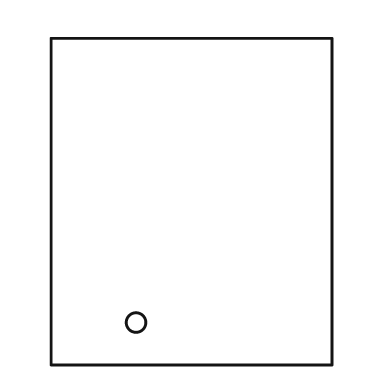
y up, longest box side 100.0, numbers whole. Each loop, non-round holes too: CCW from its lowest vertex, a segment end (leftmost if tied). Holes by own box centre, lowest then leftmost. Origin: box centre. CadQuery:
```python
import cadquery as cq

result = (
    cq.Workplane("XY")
    .moveTo(-43.0, -50.0)
    .lineTo(43.0, -50.0)
    .lineTo(43.0, 50.0)
    .lineTo(-43.0, 50.0)
    .close()
    .moveTo(-17.0, -37.0)
    .circle(3.0)
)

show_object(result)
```